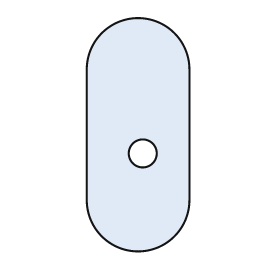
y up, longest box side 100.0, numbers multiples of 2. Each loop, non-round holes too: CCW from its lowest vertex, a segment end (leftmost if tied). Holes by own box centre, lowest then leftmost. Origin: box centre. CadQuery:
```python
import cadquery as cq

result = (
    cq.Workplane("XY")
    .moveTo(-22.0, -28.0)
    .threePointArc((0.0, -50.0), (22.0, -28.0))
    .lineTo(22.0, 28.0)
    .threePointArc((0.0, 50.0), (-22.0, 28.0))
    .close()
    .moveTo(2.0, -8.0)
    .circle(6.0)
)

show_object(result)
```